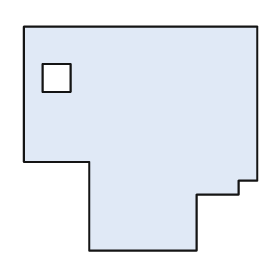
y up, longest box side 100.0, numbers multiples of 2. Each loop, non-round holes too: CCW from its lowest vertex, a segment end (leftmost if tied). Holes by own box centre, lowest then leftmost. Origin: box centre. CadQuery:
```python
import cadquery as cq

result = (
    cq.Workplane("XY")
    .moveTo(-22.0, -48.0)
    .lineTo(24.0, -48.0)
    .lineTo(24.0, -24.0)
    .lineTo(42.0, -24.0)
    .lineTo(42.0, -18.0)
    .lineTo(50.0, -18.0)
    .lineTo(50.0, 48.0)
    .lineTo(-50.0, 48.0)
    .lineTo(-50.0, -10.0)
    .lineTo(-22.0, -10.0)
    .close()
    .moveTo(-42.0, 20.0)
    .lineTo(-30.0, 20.0)
    .lineTo(-30.0, 32.0)
    .lineTo(-42.0, 32.0)
    .close()
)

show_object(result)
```